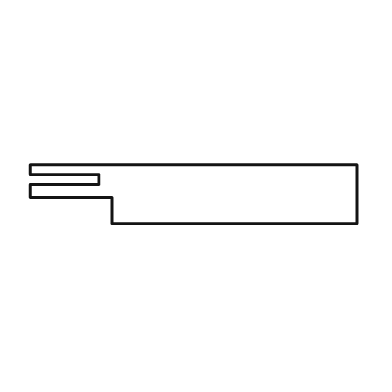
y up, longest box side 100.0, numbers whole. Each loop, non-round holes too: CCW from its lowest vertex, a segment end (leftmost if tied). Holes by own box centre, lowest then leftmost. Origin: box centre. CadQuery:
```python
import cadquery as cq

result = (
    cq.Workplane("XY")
    .moveTo(-25.0, -9.0)
    .lineTo(50.0, -9.0)
    .lineTo(50.0, 9.0)
    .lineTo(-50.0, 9.0)
    .lineTo(-50.0, 6.0)
    .lineTo(-29.0, 6.0)
    .lineTo(-29.0, 3.0)
    .lineTo(-50.0, 3.0)
    .lineTo(-50.0, -1.0)
    .lineTo(-25.0, -1.0)
    .close()
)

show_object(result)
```